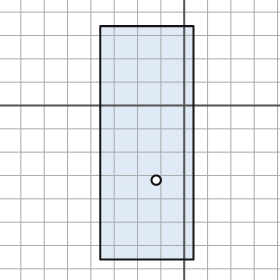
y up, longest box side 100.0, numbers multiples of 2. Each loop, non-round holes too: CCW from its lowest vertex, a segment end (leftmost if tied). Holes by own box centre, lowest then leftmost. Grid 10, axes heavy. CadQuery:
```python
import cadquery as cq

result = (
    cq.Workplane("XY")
    .moveTo(-36.0, -66.0)
    .lineTo(4.0, -66.0)
    .lineTo(4.0, 34.0)
    .lineTo(-36.0, 34.0)
    .close()
    .moveTo(-12.0, -32.0)
    .circle(2.0)
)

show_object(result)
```